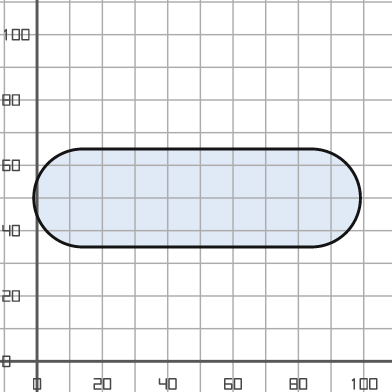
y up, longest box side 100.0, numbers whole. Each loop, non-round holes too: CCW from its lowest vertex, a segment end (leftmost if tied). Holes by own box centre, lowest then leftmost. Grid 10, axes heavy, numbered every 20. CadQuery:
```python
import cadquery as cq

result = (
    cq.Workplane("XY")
    .moveTo(14.0, 35.0)
    .lineTo(84.0, 35.0)
    .threePointArc((99.0, 50.0), (84.0, 65.0))
    .lineTo(14.0, 65.0)
    .threePointArc((-1.0, 50.0), (14.0, 35.0))
    .close()
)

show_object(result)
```